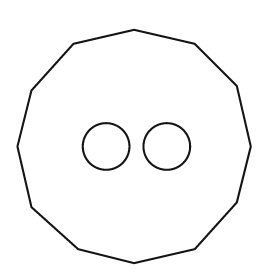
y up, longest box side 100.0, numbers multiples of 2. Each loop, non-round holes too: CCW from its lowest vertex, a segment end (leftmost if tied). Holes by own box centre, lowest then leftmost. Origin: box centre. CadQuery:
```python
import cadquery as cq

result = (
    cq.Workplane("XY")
    .moveTo(0.0, -50.0)
    .lineTo(26.0, -44.0)
    .lineTo(44.0, -24.0)
    .lineTo(50.0, 0.0)
    .lineTo(44.0, 26.0)
    .lineTo(26.0, 44.0)
    .lineTo(0.0, 50.0)
    .lineTo(-26.0, 44.0)
    .lineTo(-44.0, 24.0)
    .lineTo(-50.0, 0.0)
    .lineTo(-44.0, -26.0)
    .lineTo(-24.0, -44.0)
    .close()
    .moveTo(-12.0, 0.0)
    .circle(10.0)
    .moveTo(14.0, 0.0)
    .circle(10.0)
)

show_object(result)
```